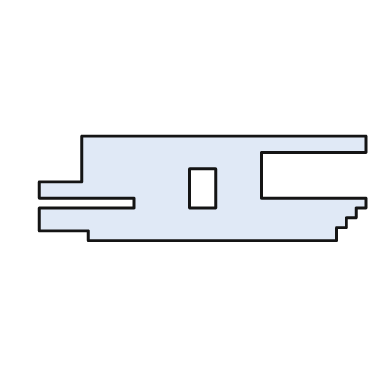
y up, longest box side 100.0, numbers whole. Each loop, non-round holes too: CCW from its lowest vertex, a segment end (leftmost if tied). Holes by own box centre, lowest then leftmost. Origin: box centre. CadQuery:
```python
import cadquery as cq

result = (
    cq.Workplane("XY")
    .moveTo(-35.0, -16.0)
    .lineTo(41.0, -16.0)
    .lineTo(41.0, -12.0)
    .lineTo(44.0, -12.0)
    .lineTo(44.0, -9.0)
    .lineTo(47.0, -9.0)
    .lineTo(47.0, -6.0)
    .lineTo(50.0, -6.0)
    .lineTo(50.0, -3.0)
    .lineTo(18.0, -3.0)
    .lineTo(18.0, 11.0)
    .lineTo(50.0, 11.0)
    .lineTo(50.0, 16.0)
    .lineTo(-37.0, 16.0)
    .lineTo(-37.0, 2.0)
    .lineTo(-50.0, 2.0)
    .lineTo(-50.0, -3.0)
    .lineTo(-21.0, -3.0)
    .lineTo(-21.0, -6.0)
    .lineTo(-50.0, -6.0)
    .lineTo(-50.0, -13.0)
    .lineTo(-35.0, -13.0)
    .close()
    .moveTo(-4.0, -6.0)
    .lineTo(4.0, -6.0)
    .lineTo(4.0, 6.0)
    .lineTo(-4.0, 6.0)
    .close()
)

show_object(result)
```